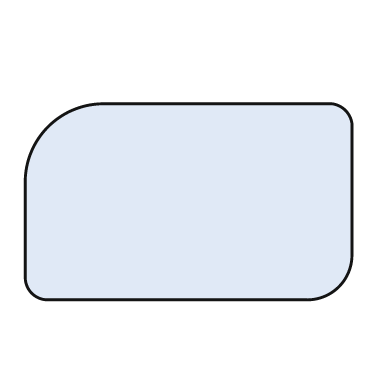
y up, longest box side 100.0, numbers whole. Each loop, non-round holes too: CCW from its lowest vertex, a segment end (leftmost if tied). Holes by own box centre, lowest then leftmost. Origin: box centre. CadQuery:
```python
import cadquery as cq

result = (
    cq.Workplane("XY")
    .moveTo(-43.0, -30.0)
    .lineTo(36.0, -30.0)
    .threePointArc((46.0, -26.0), (50.0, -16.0))
    .lineTo(50.0, 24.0)
    .threePointArc((48.0, 28.0), (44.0, 30.0))
    .lineTo(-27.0, 30.0)
    .threePointArc((-43.0, 23.0), (-50.0, 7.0))
    .lineTo(-50.0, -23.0)
    .threePointArc((-48.0, -28.0), (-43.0, -30.0))
    .close()
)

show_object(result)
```